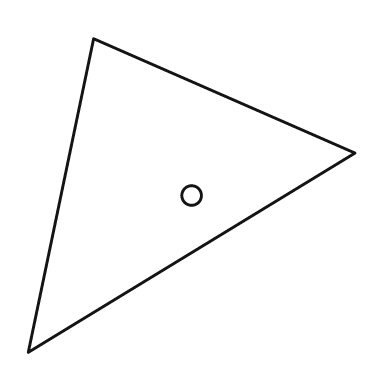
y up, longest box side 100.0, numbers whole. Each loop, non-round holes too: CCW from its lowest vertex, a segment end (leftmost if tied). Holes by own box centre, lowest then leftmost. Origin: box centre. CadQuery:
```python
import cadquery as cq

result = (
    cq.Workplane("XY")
    .moveTo(-50.0, -48.0)
    .lineTo(50.0, 13.0)
    .lineTo(-30.0, 48.0)
    .close()
    .moveTo(0.0, 0.0)
    .circle(3.0)
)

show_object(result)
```